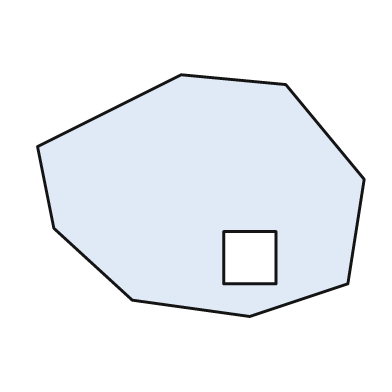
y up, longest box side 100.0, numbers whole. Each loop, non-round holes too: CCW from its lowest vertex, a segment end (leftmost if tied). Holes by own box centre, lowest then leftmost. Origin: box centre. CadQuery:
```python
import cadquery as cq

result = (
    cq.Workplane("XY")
    .moveTo(15.0, -37.0)
    .lineTo(45.0, -27.0)
    .lineTo(50.0, 5.0)
    .lineTo(26.0, 34.0)
    .lineTo(-6.0, 37.0)
    .lineTo(-50.0, 15.0)
    .lineTo(-45.0, -10.0)
    .lineTo(-21.0, -32.0)
    .close()
    .moveTo(7.0, -27.0)
    .lineTo(23.0, -27.0)
    .lineTo(23.0, -11.0)
    .lineTo(7.0, -11.0)
    .close()
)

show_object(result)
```